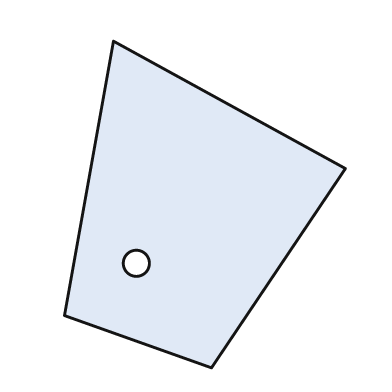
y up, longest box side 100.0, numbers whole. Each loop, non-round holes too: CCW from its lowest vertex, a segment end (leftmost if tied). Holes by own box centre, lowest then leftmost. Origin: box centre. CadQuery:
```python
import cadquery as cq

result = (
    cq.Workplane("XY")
    .moveTo(2.0, -50.0)
    .lineTo(43.0, 11.0)
    .lineTo(-28.0, 50.0)
    .lineTo(-43.0, -34.0)
    .close()
    .moveTo(-21.0, -18.0)
    .circle(4.0)
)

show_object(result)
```